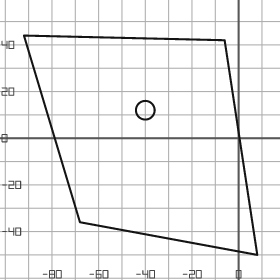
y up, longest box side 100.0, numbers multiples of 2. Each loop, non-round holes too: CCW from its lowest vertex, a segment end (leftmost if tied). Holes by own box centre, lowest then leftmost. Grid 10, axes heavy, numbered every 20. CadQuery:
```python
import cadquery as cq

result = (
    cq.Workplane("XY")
    .moveTo(8.0, -50.0)
    .lineTo(-6.0, 42.0)
    .lineTo(-92.0, 44.0)
    .lineTo(-68.0, -36.0)
    .close()
    .moveTo(-40.0, 12.0)
    .circle(4.0)
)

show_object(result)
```